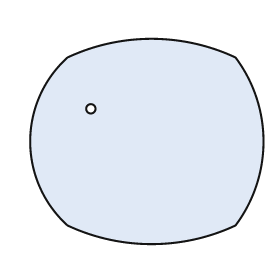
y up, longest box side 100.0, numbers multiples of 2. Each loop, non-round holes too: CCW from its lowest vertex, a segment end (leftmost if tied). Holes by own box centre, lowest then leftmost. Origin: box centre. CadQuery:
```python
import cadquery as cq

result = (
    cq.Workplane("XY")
    .moveTo(-34.0, -36.0)
    .threePointArc((2.0, -44.0), (38.0, -36.0))
    .threePointArc((50.0, 0.0), (38.0, 36.0))
    .threePointArc((2.0, 44.0), (-34.0, 36.0))
    .threePointArc((-50.0, 0.0), (-34.0, -36.0))
    .close()
    .moveTo(-24.0, 14.0)
    .circle(2.0)
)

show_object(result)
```